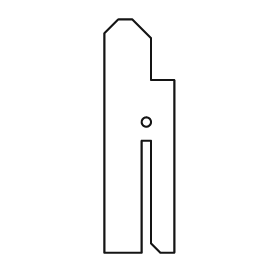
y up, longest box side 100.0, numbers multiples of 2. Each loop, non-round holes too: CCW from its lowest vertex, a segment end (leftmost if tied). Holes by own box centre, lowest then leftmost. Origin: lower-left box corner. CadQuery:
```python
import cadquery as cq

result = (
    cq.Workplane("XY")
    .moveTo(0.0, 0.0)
    .lineTo(16.0, 0.0)
    .lineTo(16.0, 48.0)
    .lineTo(20.0, 48.0)
    .lineTo(20.0, 4.0)
    .lineTo(24.0, 0.0)
    .lineTo(30.0, 0.0)
    .lineTo(30.0, 74.0)
    .lineTo(20.0, 74.0)
    .lineTo(20.0, 92.0)
    .lineTo(12.0, 100.0)
    .lineTo(6.0, 100.0)
    .lineTo(0.0, 94.0)
    .close()
    .moveTo(18.0, 56.0)
    .circle(2.0)
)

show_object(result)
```